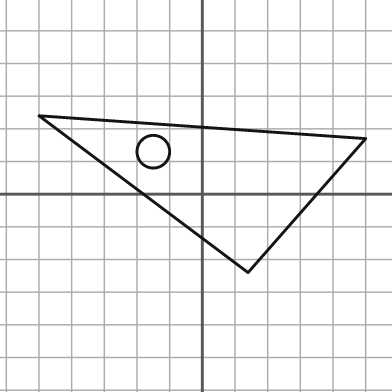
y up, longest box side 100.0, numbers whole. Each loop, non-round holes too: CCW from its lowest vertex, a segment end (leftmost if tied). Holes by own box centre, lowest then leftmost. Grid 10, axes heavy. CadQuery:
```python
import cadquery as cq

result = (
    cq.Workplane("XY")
    .moveTo(14.0, -24.0)
    .lineTo(50.0, 17.0)
    .lineTo(-50.0, 24.0)
    .close()
    .moveTo(-15.0, 13.0)
    .circle(5.0)
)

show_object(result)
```